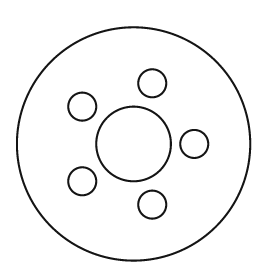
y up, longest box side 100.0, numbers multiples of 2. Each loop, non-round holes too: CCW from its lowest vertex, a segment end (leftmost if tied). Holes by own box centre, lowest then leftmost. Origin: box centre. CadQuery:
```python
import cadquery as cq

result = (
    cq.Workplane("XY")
    .moveTo(0.0, 0.0)
    .circle(50.0)
    .moveTo(8.0, -26.0)
    .circle(6.0)
    .moveTo(-22.0, -16.0)
    .circle(6.0)
    .moveTo(0.0, 0.0)
    .circle(16.0)
    .moveTo(26.0, 0.0)
    .circle(6.0)
    .moveTo(-22.0, 16.0)
    .circle(6.0)
    .moveTo(8.0, 26.0)
    .circle(6.0)
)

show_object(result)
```